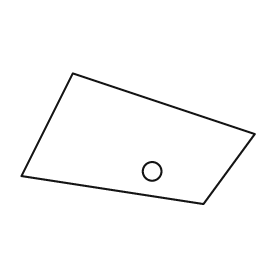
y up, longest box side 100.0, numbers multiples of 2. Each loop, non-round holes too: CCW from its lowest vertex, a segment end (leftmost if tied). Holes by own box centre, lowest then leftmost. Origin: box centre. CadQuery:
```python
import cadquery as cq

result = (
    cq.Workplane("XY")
    .moveTo(28.0, -28.0)
    .lineTo(50.0, 2.0)
    .lineTo(-28.0, 28.0)
    .lineTo(-50.0, -16.0)
    .close()
    .moveTo(6.0, -14.0)
    .circle(4.0)
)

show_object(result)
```